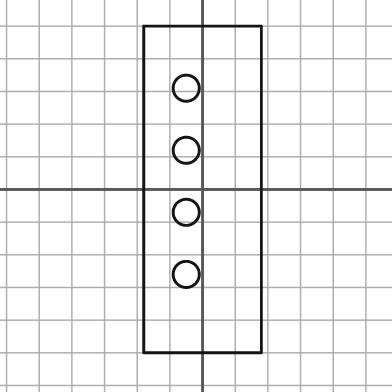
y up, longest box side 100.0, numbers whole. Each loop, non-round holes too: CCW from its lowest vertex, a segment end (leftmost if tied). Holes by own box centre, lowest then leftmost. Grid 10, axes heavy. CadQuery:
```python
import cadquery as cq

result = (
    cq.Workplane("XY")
    .moveTo(-18.0, -50.0)
    .lineTo(18.0, -50.0)
    .lineTo(18.0, 50.0)
    .lineTo(-18.0, 50.0)
    .close()
    .moveTo(-5.0, -26.0)
    .circle(4.0)
    .moveTo(-5.0, -7.0)
    .circle(4.0)
    .moveTo(-5.0, 12.0)
    .circle(4.0)
    .moveTo(-5.0, 31.0)
    .circle(4.0)
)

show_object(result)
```